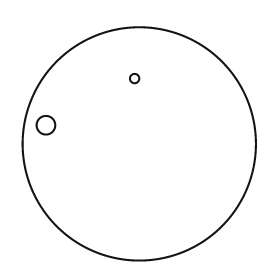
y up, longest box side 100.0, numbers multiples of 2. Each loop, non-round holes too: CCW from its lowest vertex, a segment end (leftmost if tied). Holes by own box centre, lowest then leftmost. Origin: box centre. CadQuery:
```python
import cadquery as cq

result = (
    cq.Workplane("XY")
    .moveTo(0.0, 0.0)
    .circle(50.0)
    .moveTo(-40.0, 8.0)
    .circle(4.0)
    .moveTo(-2.0, 28.0)
    .circle(2.0)
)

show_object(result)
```